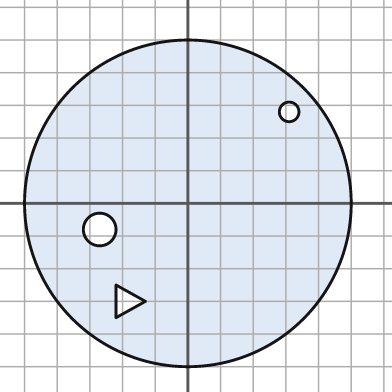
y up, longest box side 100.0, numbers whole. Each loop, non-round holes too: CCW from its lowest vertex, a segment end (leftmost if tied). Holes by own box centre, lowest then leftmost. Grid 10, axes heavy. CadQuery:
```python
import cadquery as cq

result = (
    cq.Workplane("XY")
    .moveTo(0.0, 0.0)
    .circle(50.0)
    .moveTo(-22.0, -35.0)
    .lineTo(-13.0, -30.0)
    .lineTo(-22.0, -25.0)
    .close()
    .moveTo(-27.0, -8.0)
    .circle(5.0)
    .moveTo(31.0, 28.0)
    .circle(3.0)
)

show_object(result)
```